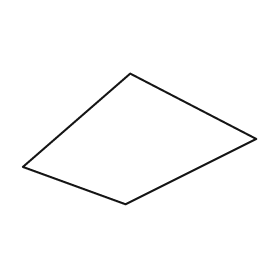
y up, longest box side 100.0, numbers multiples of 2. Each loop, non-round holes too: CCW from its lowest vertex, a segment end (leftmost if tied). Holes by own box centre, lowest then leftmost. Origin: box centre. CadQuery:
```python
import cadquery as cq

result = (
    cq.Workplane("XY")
    .moveTo(-6.0, -28.0)
    .lineTo(50.0, 0.0)
    .lineTo(-4.0, 28.0)
    .lineTo(-50.0, -12.0)
    .close()
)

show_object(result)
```